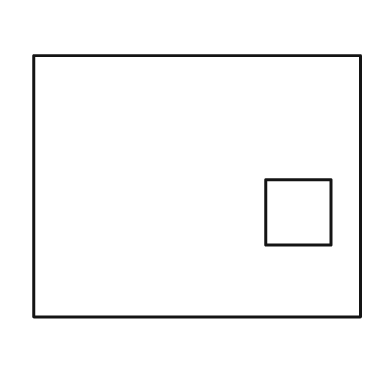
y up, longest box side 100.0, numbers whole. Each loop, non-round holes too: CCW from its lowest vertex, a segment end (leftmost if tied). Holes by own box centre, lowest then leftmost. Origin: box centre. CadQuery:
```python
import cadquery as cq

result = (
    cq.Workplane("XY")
    .moveTo(-50.0, -40.0)
    .lineTo(50.0, -40.0)
    .lineTo(50.0, 40.0)
    .lineTo(-50.0, 40.0)
    .close()
    .moveTo(21.0, -18.0)
    .lineTo(41.0, -18.0)
    .lineTo(41.0, 2.0)
    .lineTo(21.0, 2.0)
    .close()
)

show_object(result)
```